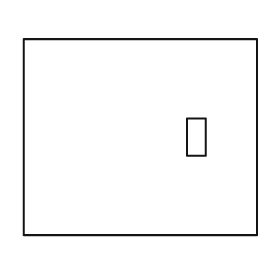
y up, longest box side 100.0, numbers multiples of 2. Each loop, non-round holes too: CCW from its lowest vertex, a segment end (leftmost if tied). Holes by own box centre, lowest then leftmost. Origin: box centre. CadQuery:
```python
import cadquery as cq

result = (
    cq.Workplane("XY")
    .moveTo(-50.0, -42.0)
    .lineTo(50.0, -42.0)
    .lineTo(50.0, 42.0)
    .lineTo(-50.0, 42.0)
    .close()
    .moveTo(20.0, -8.0)
    .lineTo(28.0, -8.0)
    .lineTo(28.0, 8.0)
    .lineTo(20.0, 8.0)
    .close()
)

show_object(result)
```